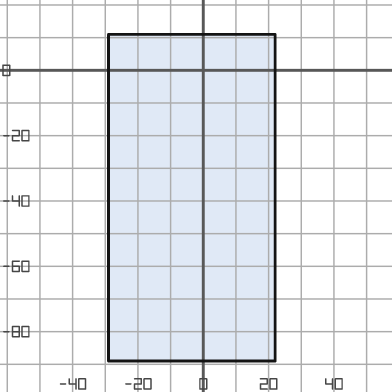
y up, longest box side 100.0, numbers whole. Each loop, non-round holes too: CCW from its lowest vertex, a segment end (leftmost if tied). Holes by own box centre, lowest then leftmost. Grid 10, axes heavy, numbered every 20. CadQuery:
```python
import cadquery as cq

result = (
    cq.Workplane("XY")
    .moveTo(-29.0, -89.0)
    .lineTo(22.0, -89.0)
    .lineTo(22.0, 11.0)
    .lineTo(-29.0, 11.0)
    .close()
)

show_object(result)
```